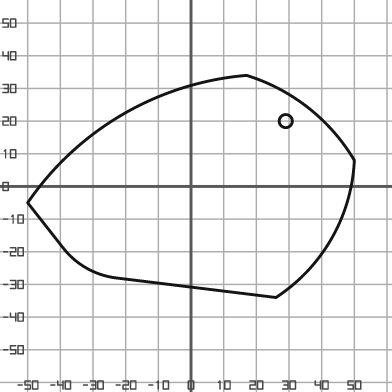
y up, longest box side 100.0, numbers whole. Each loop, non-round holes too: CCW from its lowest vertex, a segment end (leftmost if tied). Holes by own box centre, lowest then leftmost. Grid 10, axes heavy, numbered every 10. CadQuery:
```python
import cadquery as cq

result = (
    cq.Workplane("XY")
    .moveTo(26.0, -34.0)
    .threePointArc((43.0, -16.0), (50.0, 8.0))
    .threePointArc((36.0, 24.0), (17.0, 34.0))
    .threePointArc((-21.0, 22.0), (-50.0, -5.0))
    .lineTo(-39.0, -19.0)
    .threePointArc((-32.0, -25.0), (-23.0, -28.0))
    .close()
    .moveTo(29.0, 20.0)
    .circle(2.0)
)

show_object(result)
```